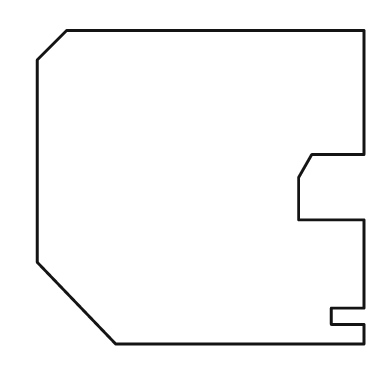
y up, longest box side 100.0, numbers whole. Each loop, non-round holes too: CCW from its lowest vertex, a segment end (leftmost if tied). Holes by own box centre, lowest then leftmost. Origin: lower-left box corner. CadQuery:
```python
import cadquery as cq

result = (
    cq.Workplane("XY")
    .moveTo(24.0, 0.0)
    .lineTo(100.0, 0.0)
    .lineTo(100.0, 6.0)
    .lineTo(90.0, 6.0)
    .lineTo(90.0, 11.0)
    .lineTo(100.0, 11.0)
    .lineTo(100.0, 38.0)
    .lineTo(80.0, 38.0)
    .lineTo(80.0, 51.0)
    .lineTo(84.0, 58.0)
    .lineTo(100.0, 58.0)
    .lineTo(100.0, 96.0)
    .lineTo(9.0, 96.0)
    .lineTo(0.0, 87.0)
    .lineTo(0.0, 25.0)
    .close()
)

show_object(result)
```